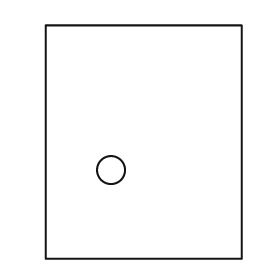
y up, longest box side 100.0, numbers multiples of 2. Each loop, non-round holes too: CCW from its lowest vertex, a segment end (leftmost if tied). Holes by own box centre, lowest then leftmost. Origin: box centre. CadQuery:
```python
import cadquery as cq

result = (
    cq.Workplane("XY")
    .moveTo(-42.0, -50.0)
    .lineTo(42.0, -50.0)
    .lineTo(42.0, 50.0)
    .lineTo(-42.0, 50.0)
    .close()
    .moveTo(-14.0, -12.0)
    .circle(6.0)
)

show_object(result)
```